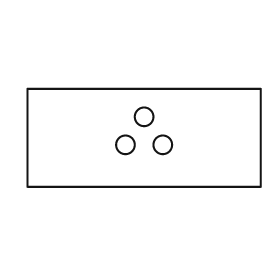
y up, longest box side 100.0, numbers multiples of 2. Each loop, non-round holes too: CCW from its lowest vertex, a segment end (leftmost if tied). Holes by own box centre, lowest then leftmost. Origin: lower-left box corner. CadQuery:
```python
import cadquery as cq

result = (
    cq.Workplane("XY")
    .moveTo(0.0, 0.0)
    .lineTo(100.0, 0.0)
    .lineTo(100.0, 42.0)
    .lineTo(0.0, 42.0)
    .close()
    .moveTo(42.0, 18.0)
    .circle(4.0)
    .moveTo(58.0, 18.0)
    .circle(4.0)
    .moveTo(50.0, 30.0)
    .circle(4.0)
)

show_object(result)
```